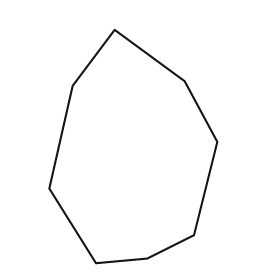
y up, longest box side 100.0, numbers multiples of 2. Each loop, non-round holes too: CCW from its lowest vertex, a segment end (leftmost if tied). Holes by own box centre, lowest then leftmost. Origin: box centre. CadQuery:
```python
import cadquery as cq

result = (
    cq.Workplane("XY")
    .moveTo(-16.0, -50.0)
    .lineTo(6.0, -48.0)
    .lineTo(26.0, -38.0)
    .lineTo(36.0, 2.0)
    .lineTo(22.0, 28.0)
    .lineTo(-8.0, 50.0)
    .lineTo(-26.0, 26.0)
    .lineTo(-36.0, -18.0)
    .close()
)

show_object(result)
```